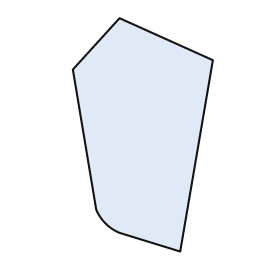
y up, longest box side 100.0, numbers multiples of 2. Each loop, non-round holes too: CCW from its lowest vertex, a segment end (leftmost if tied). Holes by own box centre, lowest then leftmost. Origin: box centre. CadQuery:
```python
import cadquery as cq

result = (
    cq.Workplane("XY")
    .moveTo(16.0, -50.0)
    .lineTo(30.0, 32.0)
    .lineTo(-10.0, 50.0)
    .lineTo(-30.0, 28.0)
    .lineTo(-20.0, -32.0)
    .threePointArc((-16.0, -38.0), (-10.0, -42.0))
    .close()
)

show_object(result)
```